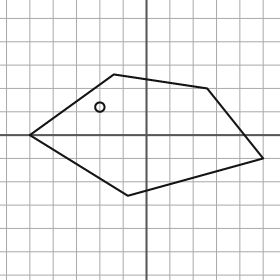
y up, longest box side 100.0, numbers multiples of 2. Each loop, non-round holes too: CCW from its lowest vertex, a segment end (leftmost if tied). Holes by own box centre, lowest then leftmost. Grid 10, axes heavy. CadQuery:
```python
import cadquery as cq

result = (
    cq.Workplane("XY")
    .moveTo(-8.0, -26.0)
    .lineTo(50.0, -10.0)
    .lineTo(26.0, 20.0)
    .lineTo(-14.0, 26.0)
    .lineTo(-50.0, 0.0)
    .close()
    .moveTo(-20.0, 12.0)
    .circle(2.0)
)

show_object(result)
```